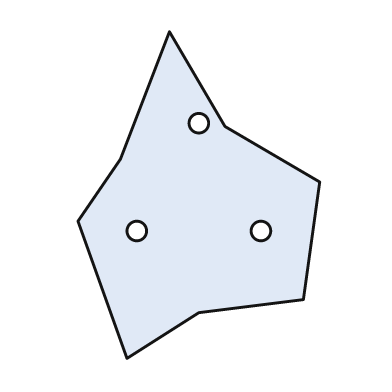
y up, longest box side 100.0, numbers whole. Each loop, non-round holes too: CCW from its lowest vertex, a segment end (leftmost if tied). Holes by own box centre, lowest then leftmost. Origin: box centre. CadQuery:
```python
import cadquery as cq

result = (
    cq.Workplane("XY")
    .moveTo(-22.0, -50.0)
    .lineTo(0.0, -36.0)
    .lineTo(32.0, -32.0)
    .lineTo(37.0, 4.0)
    .lineTo(8.0, 21.0)
    .lineTo(-9.0, 50.0)
    .lineTo(-24.0, 11.0)
    .lineTo(-37.0, -8.0)
    .close()
    .moveTo(-19.0, -11.0)
    .circle(3.0)
    .moveTo(19.0, -11.0)
    .circle(3.0)
    .moveTo(0.0, 22.0)
    .circle(3.0)
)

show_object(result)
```